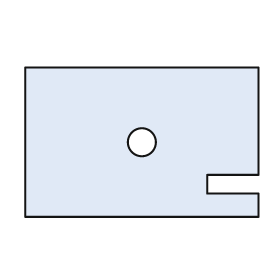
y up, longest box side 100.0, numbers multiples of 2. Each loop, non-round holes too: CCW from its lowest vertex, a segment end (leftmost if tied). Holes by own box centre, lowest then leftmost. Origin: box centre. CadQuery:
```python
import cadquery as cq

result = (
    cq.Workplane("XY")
    .moveTo(-50.0, -32.0)
    .lineTo(50.0, -32.0)
    .lineTo(50.0, -22.0)
    .lineTo(28.0, -22.0)
    .lineTo(28.0, -14.0)
    .lineTo(50.0, -14.0)
    .lineTo(50.0, 32.0)
    .lineTo(-50.0, 32.0)
    .close()
    .moveTo(0.0, 0.0)
    .circle(6.0)
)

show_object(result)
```